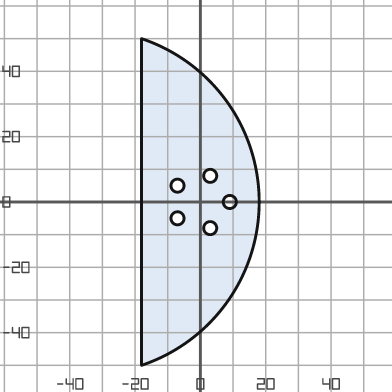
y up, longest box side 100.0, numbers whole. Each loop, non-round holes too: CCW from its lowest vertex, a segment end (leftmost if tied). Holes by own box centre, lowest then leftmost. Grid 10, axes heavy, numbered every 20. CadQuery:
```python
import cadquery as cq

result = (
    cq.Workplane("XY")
    .moveTo(-18.0, -50.0)
    .threePointArc((18.0, 0.0), (-18.0, 50.0))
    .close()
    .moveTo(3.0, -8.0)
    .circle(2.0)
    .moveTo(-7.0, -5.0)
    .circle(2.0)
    .moveTo(9.0, 0.0)
    .circle(2.0)
    .moveTo(-7.0, 5.0)
    .circle(2.0)
    .moveTo(3.0, 8.0)
    .circle(2.0)
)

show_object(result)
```